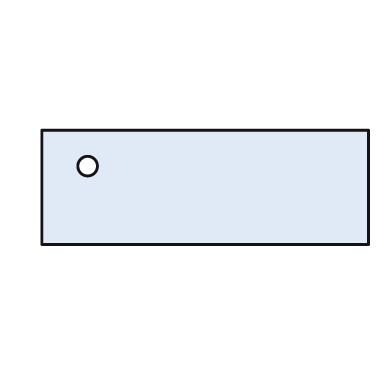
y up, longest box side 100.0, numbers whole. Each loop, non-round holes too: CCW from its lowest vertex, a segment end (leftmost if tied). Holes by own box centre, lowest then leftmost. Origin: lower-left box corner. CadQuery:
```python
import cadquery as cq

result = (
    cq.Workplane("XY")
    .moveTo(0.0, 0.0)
    .lineTo(100.0, 0.0)
    .lineTo(100.0, 35.0)
    .lineTo(0.0, 35.0)
    .close()
    .moveTo(14.0, 24.0)
    .circle(3.0)
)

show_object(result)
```